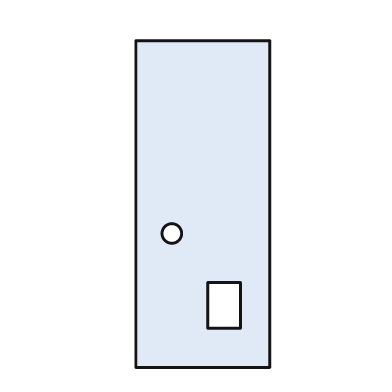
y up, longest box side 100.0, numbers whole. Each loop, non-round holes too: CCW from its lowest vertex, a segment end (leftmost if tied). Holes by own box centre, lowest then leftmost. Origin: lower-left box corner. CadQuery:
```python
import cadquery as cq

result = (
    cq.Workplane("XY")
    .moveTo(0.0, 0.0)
    .lineTo(41.0, 0.0)
    .lineTo(41.0, 100.0)
    .lineTo(0.0, 100.0)
    .close()
    .moveTo(22.0, 12.0)
    .lineTo(32.0, 12.0)
    .lineTo(32.0, 26.0)
    .lineTo(22.0, 26.0)
    .close()
    .moveTo(11.0, 41.0)
    .circle(3.0)
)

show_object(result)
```